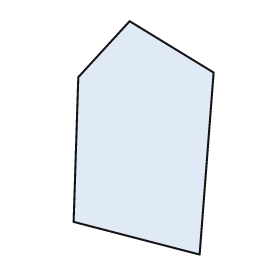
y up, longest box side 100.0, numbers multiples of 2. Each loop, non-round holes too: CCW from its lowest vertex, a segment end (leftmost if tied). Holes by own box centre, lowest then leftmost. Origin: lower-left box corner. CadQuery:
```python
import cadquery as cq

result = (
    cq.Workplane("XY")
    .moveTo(54.0, 0.0)
    .lineTo(60.0, 78.0)
    .lineTo(24.0, 100.0)
    .lineTo(2.0, 76.0)
    .lineTo(0.0, 14.0)
    .close()
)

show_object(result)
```